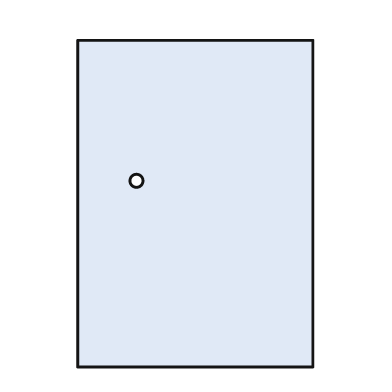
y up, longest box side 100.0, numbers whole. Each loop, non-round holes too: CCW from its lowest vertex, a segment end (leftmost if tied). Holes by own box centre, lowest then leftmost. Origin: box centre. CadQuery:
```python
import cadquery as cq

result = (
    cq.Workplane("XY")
    .moveTo(-36.0, -50.0)
    .lineTo(36.0, -50.0)
    .lineTo(36.0, 50.0)
    .lineTo(-36.0, 50.0)
    .close()
    .moveTo(-18.0, 7.0)
    .circle(2.0)
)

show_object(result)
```